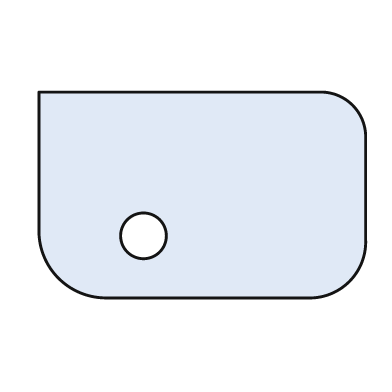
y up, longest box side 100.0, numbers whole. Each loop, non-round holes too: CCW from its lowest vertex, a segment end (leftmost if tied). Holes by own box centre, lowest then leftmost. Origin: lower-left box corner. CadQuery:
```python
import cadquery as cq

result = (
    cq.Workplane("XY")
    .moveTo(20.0, 0.0)
    .lineTo(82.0, 0.0)
    .threePointArc((95.0, 5.0), (100.0, 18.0))
    .lineTo(100.0, 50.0)
    .threePointArc((96.0, 59.0), (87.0, 63.0))
    .lineTo(0.0, 63.0)
    .lineTo(0.0, 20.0)
    .threePointArc((6.0, 6.0), (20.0, 0.0))
    .close()
    .moveTo(32.0, 19.0)
    .circle(7.0)
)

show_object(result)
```